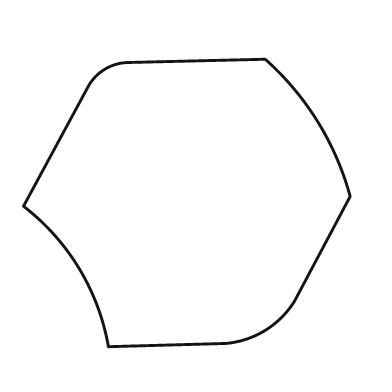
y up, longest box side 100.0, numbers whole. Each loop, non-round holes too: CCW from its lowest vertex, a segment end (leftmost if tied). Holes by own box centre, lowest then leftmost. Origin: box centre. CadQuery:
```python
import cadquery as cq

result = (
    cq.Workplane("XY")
    .moveTo(-24.0, -44.0)
    .lineTo(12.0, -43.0)
    .threePointArc((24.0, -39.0), (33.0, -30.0))
    .lineTo(50.0, 2.0)
    .threePointArc((40.0, 25.0), (24.0, 44.0))
    .lineTo(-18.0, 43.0)
    .threePointArc((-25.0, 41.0), (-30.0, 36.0))
    .lineTo(-50.0, -1.0)
    .threePointArc((-33.0, -20.0), (-24.0, -44.0))
    .close()
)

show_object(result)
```